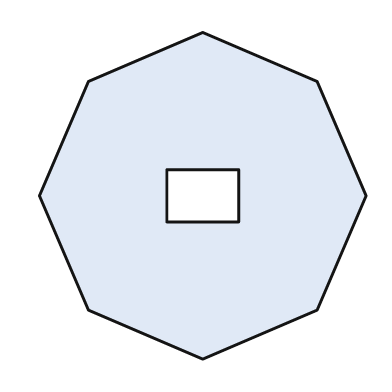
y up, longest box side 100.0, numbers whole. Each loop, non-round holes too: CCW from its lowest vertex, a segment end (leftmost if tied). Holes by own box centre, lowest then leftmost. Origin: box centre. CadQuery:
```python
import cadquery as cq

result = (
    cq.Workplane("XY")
    .moveTo(0.0, -50.0)
    .lineTo(35.0, -35.0)
    .lineTo(50.0, 0.0)
    .lineTo(35.0, 35.0)
    .lineTo(0.0, 50.0)
    .lineTo(-35.0, 35.0)
    .lineTo(-50.0, 0.0)
    .lineTo(-35.0, -35.0)
    .close()
    .moveTo(-11.0, -8.0)
    .lineTo(11.0, -8.0)
    .lineTo(11.0, 8.0)
    .lineTo(-11.0, 8.0)
    .close()
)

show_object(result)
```